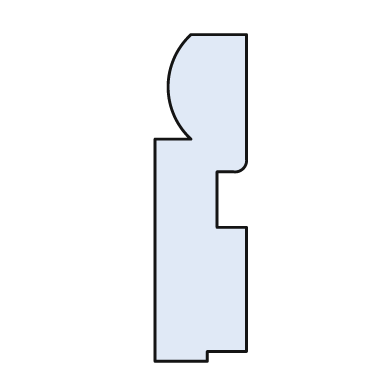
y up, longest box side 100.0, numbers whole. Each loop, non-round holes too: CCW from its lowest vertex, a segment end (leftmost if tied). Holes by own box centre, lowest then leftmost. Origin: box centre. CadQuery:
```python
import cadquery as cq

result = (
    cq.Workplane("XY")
    .moveTo(-14.0, -50.0)
    .lineTo(2.0, -50.0)
    .lineTo(2.0, -47.0)
    .lineTo(14.0, -47.0)
    .lineTo(14.0, -9.0)
    .lineTo(5.0, -9.0)
    .lineTo(5.0, 8.0)
    .lineTo(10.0, 8.0)
    .threePointArc((13.0, 9.0), (14.0, 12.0))
    .lineTo(14.0, 50.0)
    .lineTo(-3.0, 50.0)
    .threePointArc((-10.0, 34.0), (-3.0, 18.0))
    .lineTo(-14.0, 18.0)
    .close()
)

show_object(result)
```